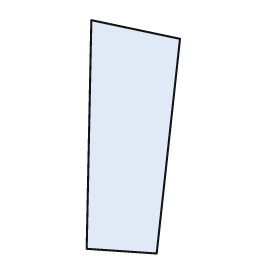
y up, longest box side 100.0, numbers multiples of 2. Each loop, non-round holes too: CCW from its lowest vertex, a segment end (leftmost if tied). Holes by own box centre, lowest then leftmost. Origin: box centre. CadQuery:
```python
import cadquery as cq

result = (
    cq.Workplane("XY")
    .moveTo(10.0, -50.0)
    .lineTo(20.0, 42.0)
    .lineTo(-18.0, 50.0)
    .lineTo(-20.0, -48.0)
    .close()
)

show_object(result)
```